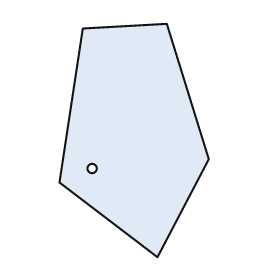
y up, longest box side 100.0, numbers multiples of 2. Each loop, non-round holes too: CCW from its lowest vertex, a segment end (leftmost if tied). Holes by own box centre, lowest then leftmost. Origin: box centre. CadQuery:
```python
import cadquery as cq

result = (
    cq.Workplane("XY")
    .moveTo(10.0, -50.0)
    .lineTo(32.0, -8.0)
    .lineTo(14.0, 50.0)
    .lineTo(-22.0, 48.0)
    .lineTo(-32.0, -18.0)
    .close()
    .moveTo(-18.0, -12.0)
    .circle(2.0)
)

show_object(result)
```